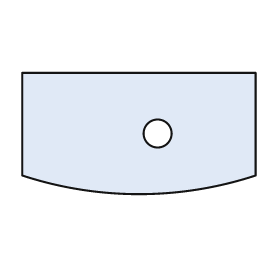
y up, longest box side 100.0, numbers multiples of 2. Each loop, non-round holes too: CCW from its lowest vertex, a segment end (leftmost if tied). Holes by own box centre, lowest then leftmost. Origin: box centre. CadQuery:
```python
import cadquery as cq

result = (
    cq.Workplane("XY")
    .moveTo(-50.0, -18.0)
    .threePointArc((0.0, -26.0), (50.0, -18.0))
    .lineTo(50.0, 26.0)
    .lineTo(-50.0, 26.0)
    .close()
    .moveTo(8.0, 0.0)
    .circle(6.0)
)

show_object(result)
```